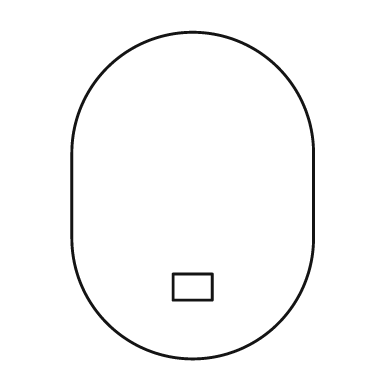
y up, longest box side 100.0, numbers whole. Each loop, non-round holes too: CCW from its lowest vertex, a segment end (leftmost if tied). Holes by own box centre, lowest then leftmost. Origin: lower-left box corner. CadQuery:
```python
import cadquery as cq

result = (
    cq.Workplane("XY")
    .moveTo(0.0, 37.0)
    .threePointArc((37.0, 0.0), (74.0, 37.0))
    .lineTo(74.0, 63.0)
    .threePointArc((37.0, 100.0), (0.0, 63.0))
    .close()
    .moveTo(31.0, 18.0)
    .lineTo(43.0, 18.0)
    .lineTo(43.0, 26.0)
    .lineTo(31.0, 26.0)
    .close()
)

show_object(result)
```